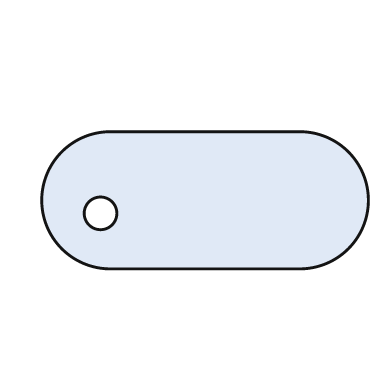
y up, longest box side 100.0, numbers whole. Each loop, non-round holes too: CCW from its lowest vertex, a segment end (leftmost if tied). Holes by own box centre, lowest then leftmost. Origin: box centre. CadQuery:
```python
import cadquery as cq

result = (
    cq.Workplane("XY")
    .moveTo(-29.0, -21.0)
    .lineTo(29.0, -21.0)
    .threePointArc((50.0, 0.0), (29.0, 21.0))
    .lineTo(-29.0, 21.0)
    .threePointArc((-50.0, 0.0), (-29.0, -21.0))
    .close()
    .moveTo(-32.0, -4.0)
    .circle(5.0)
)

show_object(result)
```